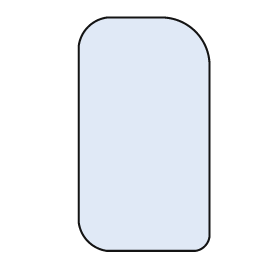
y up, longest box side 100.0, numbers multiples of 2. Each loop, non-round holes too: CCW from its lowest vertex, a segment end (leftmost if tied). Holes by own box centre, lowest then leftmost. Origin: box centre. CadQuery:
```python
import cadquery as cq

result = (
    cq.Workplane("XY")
    .moveTo(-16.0, -50.0)
    .lineTo(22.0, -50.0)
    .threePointArc((26.0, -48.0), (28.0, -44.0))
    .lineTo(28.0, 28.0)
    .threePointArc((22.0, 44.0), (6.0, 50.0))
    .lineTo(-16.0, 50.0)
    .threePointArc((-24.0, 46.0), (-28.0, 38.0))
    .lineTo(-28.0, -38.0)
    .threePointArc((-24.0, -46.0), (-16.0, -50.0))
    .close()
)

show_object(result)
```